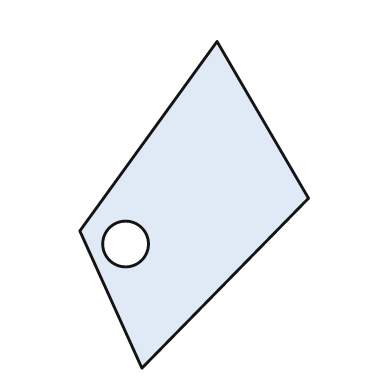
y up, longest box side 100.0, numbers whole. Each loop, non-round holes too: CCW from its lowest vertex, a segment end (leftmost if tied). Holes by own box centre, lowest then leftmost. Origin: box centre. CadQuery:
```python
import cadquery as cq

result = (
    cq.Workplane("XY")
    .moveTo(-16.0, -50.0)
    .lineTo(35.0, 2.0)
    .lineTo(7.0, 50.0)
    .lineTo(-35.0, -8.0)
    .close()
    .moveTo(-21.0, -12.0)
    .circle(7.0)
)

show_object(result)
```